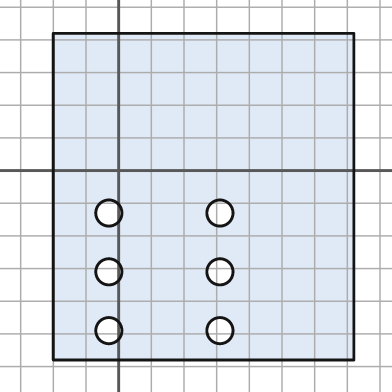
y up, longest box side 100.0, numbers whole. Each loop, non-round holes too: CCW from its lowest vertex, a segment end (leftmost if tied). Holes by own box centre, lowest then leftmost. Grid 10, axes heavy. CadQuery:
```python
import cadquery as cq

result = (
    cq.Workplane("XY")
    .moveTo(-20.0, -58.0)
    .lineTo(72.0, -58.0)
    .lineTo(72.0, 42.0)
    .lineTo(-20.0, 42.0)
    .close()
    .moveTo(-3.0, -49.0)
    .circle(4.0)
    .moveTo(31.0, -49.0)
    .circle(4.0)
    .moveTo(-3.0, -31.0)
    .circle(4.0)
    .moveTo(31.0, -31.0)
    .circle(4.0)
    .moveTo(-3.0, -13.0)
    .circle(4.0)
    .moveTo(31.0, -13.0)
    .circle(4.0)
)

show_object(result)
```